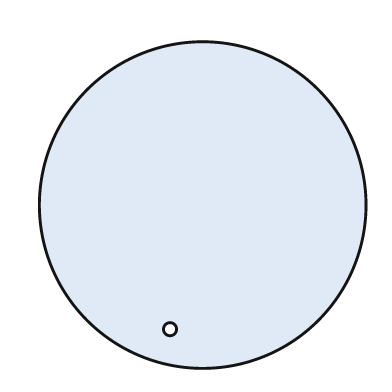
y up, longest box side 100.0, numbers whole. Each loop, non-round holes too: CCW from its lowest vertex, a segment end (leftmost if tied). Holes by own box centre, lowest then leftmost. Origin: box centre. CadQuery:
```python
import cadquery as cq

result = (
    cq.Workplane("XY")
    .moveTo(0.0, 0.0)
    .circle(50.0)
    .moveTo(-10.0, -38.0)
    .circle(2.0)
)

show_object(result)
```